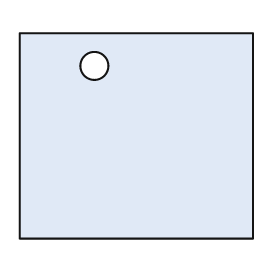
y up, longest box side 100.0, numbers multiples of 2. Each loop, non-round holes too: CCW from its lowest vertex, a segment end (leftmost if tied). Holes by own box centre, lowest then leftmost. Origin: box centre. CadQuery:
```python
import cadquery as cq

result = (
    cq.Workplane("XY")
    .moveTo(-50.0, -44.0)
    .lineTo(50.0, -44.0)
    .lineTo(50.0, 44.0)
    .lineTo(-50.0, 44.0)
    .close()
    .moveTo(-18.0, 30.0)
    .circle(6.0)
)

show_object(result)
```